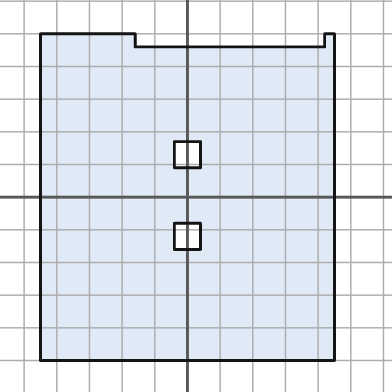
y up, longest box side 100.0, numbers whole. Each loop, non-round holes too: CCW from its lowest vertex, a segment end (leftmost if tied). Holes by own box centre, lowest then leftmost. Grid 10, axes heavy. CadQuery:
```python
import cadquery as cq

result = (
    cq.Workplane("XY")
    .moveTo(-45.0, -50.0)
    .lineTo(45.0, -50.0)
    .lineTo(45.0, 50.0)
    .lineTo(42.0, 50.0)
    .lineTo(42.0, 46.0)
    .lineTo(-16.0, 46.0)
    .lineTo(-16.0, 50.0)
    .lineTo(-45.0, 50.0)
    .close()
    .moveTo(-4.0, -16.0)
    .lineTo(4.0, -16.0)
    .lineTo(4.0, -8.0)
    .lineTo(-4.0, -8.0)
    .close()
    .moveTo(-4.0, 9.0)
    .lineTo(4.0, 9.0)
    .lineTo(4.0, 17.0)
    .lineTo(-4.0, 17.0)
    .close()
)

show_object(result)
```